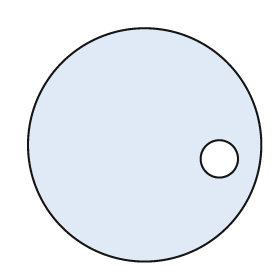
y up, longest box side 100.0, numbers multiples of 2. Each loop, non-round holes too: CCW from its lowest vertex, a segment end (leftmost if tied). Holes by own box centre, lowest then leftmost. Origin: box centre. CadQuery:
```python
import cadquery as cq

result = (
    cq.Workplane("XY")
    .moveTo(0.0, 0.0)
    .circle(50.0)
    .moveTo(32.0, -6.0)
    .circle(8.0)
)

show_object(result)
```